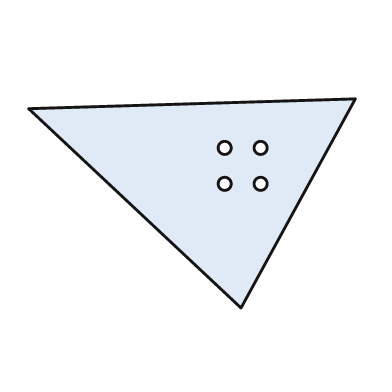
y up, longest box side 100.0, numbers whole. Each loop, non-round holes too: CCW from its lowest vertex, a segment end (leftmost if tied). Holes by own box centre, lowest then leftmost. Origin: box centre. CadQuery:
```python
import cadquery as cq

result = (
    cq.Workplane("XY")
    .moveTo(15.0, -32.0)
    .lineTo(50.0, 32.0)
    .lineTo(-50.0, 29.0)
    .close()
    .moveTo(10.0, 6.0)
    .circle(2.0)
    .moveTo(21.0, 6.0)
    .circle(2.0)
    .moveTo(10.0, 17.0)
    .circle(2.0)
    .moveTo(21.0, 17.0)
    .circle(2.0)
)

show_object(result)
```